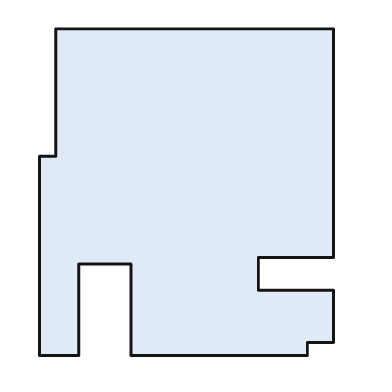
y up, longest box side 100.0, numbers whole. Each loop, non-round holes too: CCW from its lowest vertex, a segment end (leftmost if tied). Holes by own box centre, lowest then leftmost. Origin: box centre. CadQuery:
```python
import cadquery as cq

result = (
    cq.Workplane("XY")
    .moveTo(-45.0, -50.0)
    .lineTo(-33.0, -50.0)
    .lineTo(-33.0, -22.0)
    .lineTo(-17.0, -22.0)
    .lineTo(-17.0, -50.0)
    .lineTo(37.0, -50.0)
    .lineTo(37.0, -46.0)
    .lineTo(45.0, -46.0)
    .lineTo(45.0, -30.0)
    .lineTo(22.0, -30.0)
    .lineTo(22.0, -20.0)
    .lineTo(45.0, -20.0)
    .lineTo(45.0, 50.0)
    .lineTo(-40.0, 50.0)
    .lineTo(-40.0, 11.0)
    .lineTo(-45.0, 11.0)
    .close()
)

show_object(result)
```